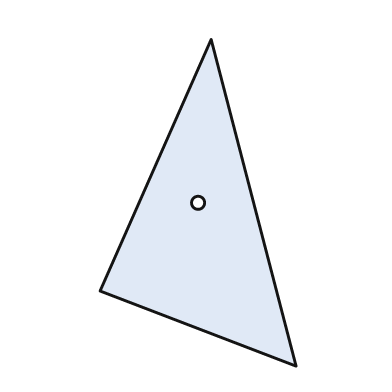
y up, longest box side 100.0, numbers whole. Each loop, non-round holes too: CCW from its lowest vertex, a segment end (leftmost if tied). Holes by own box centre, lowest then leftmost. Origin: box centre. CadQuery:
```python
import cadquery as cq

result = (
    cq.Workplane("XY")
    .moveTo(30.0, -50.0)
    .lineTo(4.0, 50.0)
    .lineTo(-30.0, -27.0)
    .close()
    .moveTo(0.0, 0.0)
    .circle(2.0)
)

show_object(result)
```